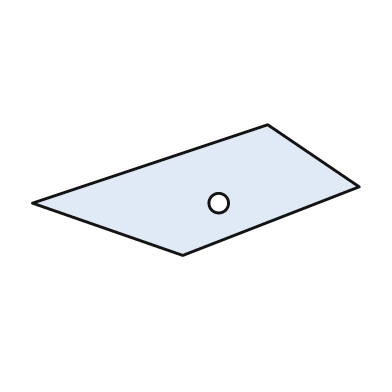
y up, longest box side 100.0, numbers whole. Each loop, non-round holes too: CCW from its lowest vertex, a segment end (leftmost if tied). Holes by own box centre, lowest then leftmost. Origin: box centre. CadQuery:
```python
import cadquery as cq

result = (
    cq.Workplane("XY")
    .moveTo(-4.0, -20.0)
    .lineTo(50.0, 1.0)
    .lineTo(22.0, 20.0)
    .lineTo(-50.0, -4.0)
    .close()
    .moveTo(7.0, -4.0)
    .circle(3.0)
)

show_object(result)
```